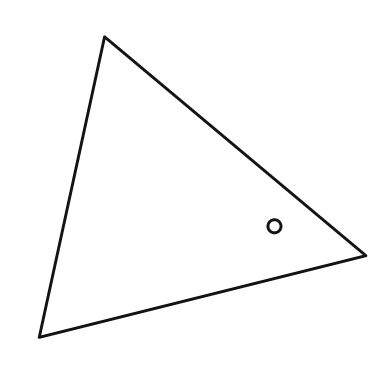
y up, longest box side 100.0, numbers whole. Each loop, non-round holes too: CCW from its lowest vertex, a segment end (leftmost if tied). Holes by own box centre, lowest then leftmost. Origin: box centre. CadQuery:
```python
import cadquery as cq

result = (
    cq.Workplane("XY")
    .moveTo(-50.0, -46.0)
    .lineTo(50.0, -21.0)
    .lineTo(-30.0, 46.0)
    .close()
    .moveTo(22.0, -12.0)
    .circle(2.0)
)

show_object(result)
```